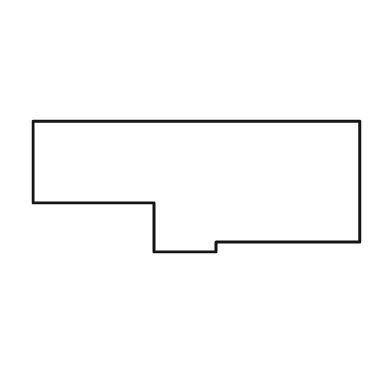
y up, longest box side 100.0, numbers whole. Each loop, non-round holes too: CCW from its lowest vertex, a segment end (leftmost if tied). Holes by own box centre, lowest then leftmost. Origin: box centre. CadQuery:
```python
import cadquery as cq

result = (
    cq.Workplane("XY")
    .moveTo(-13.0, -20.0)
    .lineTo(6.0, -20.0)
    .lineTo(6.0, -17.0)
    .lineTo(50.0, -17.0)
    .lineTo(50.0, 20.0)
    .lineTo(-50.0, 20.0)
    .lineTo(-50.0, -5.0)
    .lineTo(-13.0, -5.0)
    .close()
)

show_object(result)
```